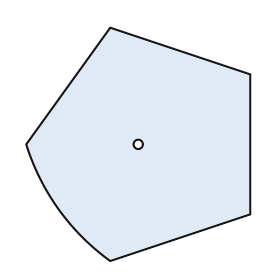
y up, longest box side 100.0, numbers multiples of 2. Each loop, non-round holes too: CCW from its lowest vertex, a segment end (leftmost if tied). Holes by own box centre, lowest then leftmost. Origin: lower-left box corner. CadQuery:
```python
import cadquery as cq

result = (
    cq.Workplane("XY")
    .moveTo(36.0, 0.0)
    .lineTo(96.0, 20.0)
    .lineTo(96.0, 80.0)
    .lineTo(36.0, 100.0)
    .lineTo(0.0, 50.0)
    .threePointArc((14.0, 22.0), (36.0, 0.0))
    .close()
    .moveTo(48.0, 50.0)
    .circle(2.0)
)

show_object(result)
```